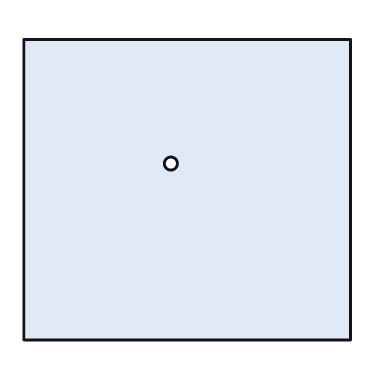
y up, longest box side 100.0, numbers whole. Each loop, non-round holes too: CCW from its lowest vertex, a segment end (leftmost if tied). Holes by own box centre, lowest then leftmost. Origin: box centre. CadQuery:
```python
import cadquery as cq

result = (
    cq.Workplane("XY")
    .moveTo(-50.0, -46.0)
    .lineTo(50.0, -46.0)
    .lineTo(50.0, 46.0)
    .lineTo(-50.0, 46.0)
    .close()
    .moveTo(-5.0, 8.0)
    .circle(2.0)
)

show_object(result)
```